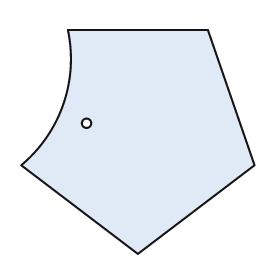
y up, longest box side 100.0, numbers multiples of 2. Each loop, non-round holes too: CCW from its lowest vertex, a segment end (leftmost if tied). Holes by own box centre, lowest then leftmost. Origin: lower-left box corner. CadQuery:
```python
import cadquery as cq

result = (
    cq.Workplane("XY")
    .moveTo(50.0, 0.0)
    .lineTo(100.0, 38.0)
    .lineTo(80.0, 96.0)
    .lineTo(20.0, 96.0)
    .threePointArc((18.0, 64.0), (0.0, 38.0))
    .close()
    .moveTo(28.0, 56.0)
    .circle(2.0)
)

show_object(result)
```